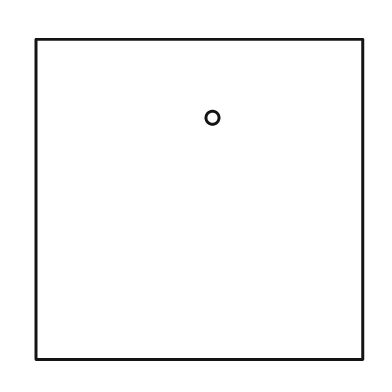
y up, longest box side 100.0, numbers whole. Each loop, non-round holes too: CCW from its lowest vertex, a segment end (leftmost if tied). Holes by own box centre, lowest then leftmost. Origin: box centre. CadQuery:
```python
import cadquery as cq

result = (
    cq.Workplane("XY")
    .moveTo(-50.0, -49.0)
    .lineTo(50.0, -49.0)
    .lineTo(50.0, 49.0)
    .lineTo(-50.0, 49.0)
    .close()
    .moveTo(4.0, 25.0)
    .circle(2.0)
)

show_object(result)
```